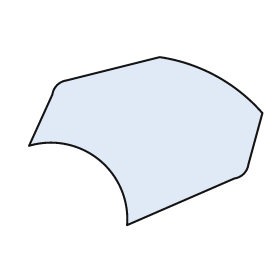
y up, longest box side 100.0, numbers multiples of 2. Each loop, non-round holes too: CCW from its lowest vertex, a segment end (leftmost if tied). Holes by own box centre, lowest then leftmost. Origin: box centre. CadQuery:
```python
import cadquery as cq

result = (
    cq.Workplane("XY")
    .moveTo(-8.0, -36.0)
    .lineTo(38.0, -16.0)
    .threePointArc((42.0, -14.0), (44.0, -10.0))
    .lineTo(50.0, 12.0)
    .threePointArc((30.0, 28.0), (6.0, 36.0))
    .lineTo(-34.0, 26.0)
    .threePointArc((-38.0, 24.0), (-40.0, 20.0))
    .lineTo(-50.0, -2.0)
    .threePointArc((-20.0, -8.0), (-8.0, -36.0))
    .close()
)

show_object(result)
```